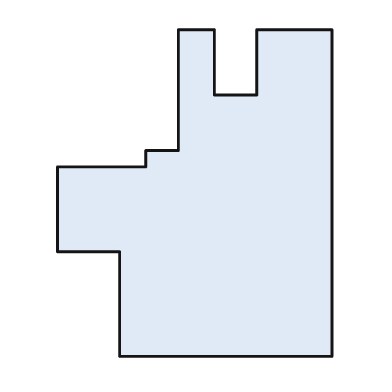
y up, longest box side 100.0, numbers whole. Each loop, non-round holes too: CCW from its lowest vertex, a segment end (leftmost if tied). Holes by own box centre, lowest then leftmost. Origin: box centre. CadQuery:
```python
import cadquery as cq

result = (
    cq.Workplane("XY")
    .moveTo(-23.0, -50.0)
    .lineTo(42.0, -50.0)
    .lineTo(42.0, 50.0)
    .lineTo(19.0, 50.0)
    .lineTo(19.0, 30.0)
    .lineTo(6.0, 30.0)
    .lineTo(6.0, 50.0)
    .lineTo(-5.0, 50.0)
    .lineTo(-5.0, 13.0)
    .lineTo(-15.0, 13.0)
    .lineTo(-15.0, 8.0)
    .lineTo(-42.0, 8.0)
    .lineTo(-42.0, -18.0)
    .lineTo(-23.0, -18.0)
    .close()
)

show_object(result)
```